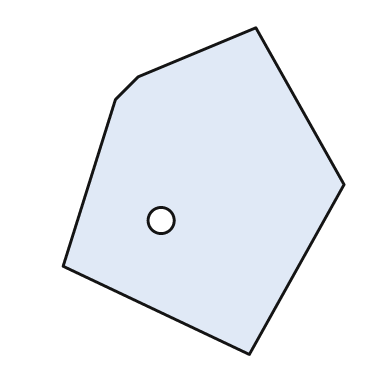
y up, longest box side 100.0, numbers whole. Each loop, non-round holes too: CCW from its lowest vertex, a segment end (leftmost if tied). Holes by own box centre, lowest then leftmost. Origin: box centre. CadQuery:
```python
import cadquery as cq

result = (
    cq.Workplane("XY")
    .moveTo(14.0, -50.0)
    .lineTo(43.0, 2.0)
    .lineTo(16.0, 50.0)
    .lineTo(-20.0, 35.0)
    .lineTo(-27.0, 28.0)
    .lineTo(-43.0, -23.0)
    .close()
    .moveTo(-13.0, -9.0)
    .circle(4.0)
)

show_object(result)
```